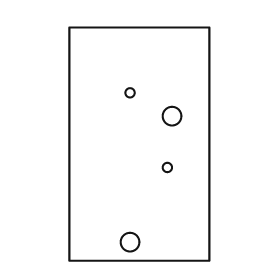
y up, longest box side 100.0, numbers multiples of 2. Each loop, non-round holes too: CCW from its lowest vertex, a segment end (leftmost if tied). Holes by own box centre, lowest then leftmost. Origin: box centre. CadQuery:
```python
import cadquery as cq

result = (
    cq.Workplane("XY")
    .moveTo(-30.0, -50.0)
    .lineTo(30.0, -50.0)
    .lineTo(30.0, 50.0)
    .lineTo(-30.0, 50.0)
    .close()
    .moveTo(-4.0, -42.0)
    .circle(4.0)
    .moveTo(12.0, -10.0)
    .circle(2.0)
    .moveTo(14.0, 12.0)
    .circle(4.0)
    .moveTo(-4.0, 22.0)
    .circle(2.0)
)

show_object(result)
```